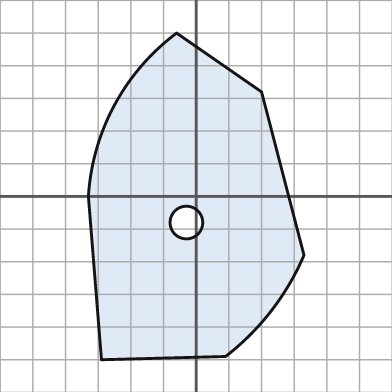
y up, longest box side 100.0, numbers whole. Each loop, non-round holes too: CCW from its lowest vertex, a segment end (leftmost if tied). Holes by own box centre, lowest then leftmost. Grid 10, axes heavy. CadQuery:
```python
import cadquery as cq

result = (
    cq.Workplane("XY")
    .moveTo(-29.0, -50.0)
    .lineTo(9.0, -49.0)
    .threePointArc((23.0, -35.0), (33.0, -18.0))
    .lineTo(20.0, 32.0)
    .lineTo(-6.0, 50.0)
    .threePointArc((-25.0, 28.0), (-33.0, 0.0))
    .close()
    .moveTo(-3.0, -8.0)
    .circle(5.0)
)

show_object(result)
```